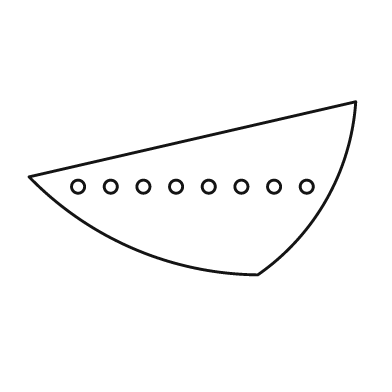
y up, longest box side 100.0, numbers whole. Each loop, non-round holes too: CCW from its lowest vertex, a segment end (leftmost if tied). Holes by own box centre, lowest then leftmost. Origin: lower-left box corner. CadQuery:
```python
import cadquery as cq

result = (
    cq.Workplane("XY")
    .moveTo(70.0, 0.0)
    .threePointArc((91.0, 23.0), (100.0, 53.0))
    .lineTo(0.0, 30.0)
    .threePointArc((32.0, 8.0), (70.0, 0.0))
    .close()
    .moveTo(15.0, 27.0)
    .circle(2.0)
    .moveTo(25.0, 27.0)
    .circle(2.0)
    .moveTo(35.0, 27.0)
    .circle(2.0)
    .moveTo(45.0, 27.0)
    .circle(2.0)
    .moveTo(55.0, 27.0)
    .circle(2.0)
    .moveTo(65.0, 27.0)
    .circle(2.0)
    .moveTo(75.0, 27.0)
    .circle(2.0)
    .moveTo(85.0, 27.0)
    .circle(2.0)
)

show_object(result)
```